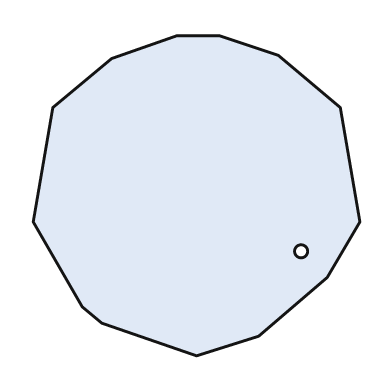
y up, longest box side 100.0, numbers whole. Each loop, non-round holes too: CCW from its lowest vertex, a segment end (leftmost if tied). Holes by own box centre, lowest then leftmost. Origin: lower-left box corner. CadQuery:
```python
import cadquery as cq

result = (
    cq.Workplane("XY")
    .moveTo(50.0, 0.0)
    .lineTo(69.0, 6.0)
    .lineTo(90.0, 24.0)
    .lineTo(100.0, 41.0)
    .lineTo(94.0, 76.0)
    .lineTo(75.0, 92.0)
    .lineTo(57.0, 98.0)
    .lineTo(44.0, 98.0)
    .lineTo(24.0, 91.0)
    .lineTo(6.0, 76.0)
    .lineTo(0.0, 41.0)
    .lineTo(15.0, 15.0)
    .lineTo(21.0, 10.0)
    .close()
    .moveTo(82.0, 32.0)
    .circle(2.0)
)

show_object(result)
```